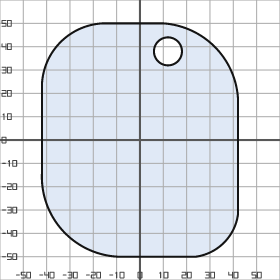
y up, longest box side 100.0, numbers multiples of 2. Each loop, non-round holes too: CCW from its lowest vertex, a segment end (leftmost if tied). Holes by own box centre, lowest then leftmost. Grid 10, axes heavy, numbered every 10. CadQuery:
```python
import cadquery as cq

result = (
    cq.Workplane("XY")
    .moveTo(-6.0, -50.0)
    .lineTo(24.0, -50.0)
    .threePointArc((36.0, -44.0), (42.0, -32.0))
    .lineTo(42.0, 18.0)
    .threePointArc((32.0, 40.0), (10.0, 50.0))
    .lineTo(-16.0, 50.0)
    .threePointArc((-34.0, 42.0), (-42.0, 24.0))
    .lineTo(-42.0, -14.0)
    .threePointArc((-32.0, -40.0), (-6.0, -50.0))
    .close()
    .moveTo(12.0, 38.0)
    .circle(6.0)
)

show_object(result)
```